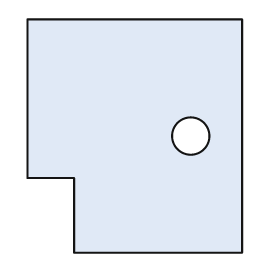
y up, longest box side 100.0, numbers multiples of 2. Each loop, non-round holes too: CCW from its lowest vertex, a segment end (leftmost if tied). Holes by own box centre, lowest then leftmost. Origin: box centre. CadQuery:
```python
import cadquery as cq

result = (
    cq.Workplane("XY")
    .moveTo(-26.0, -50.0)
    .lineTo(46.0, -50.0)
    .lineTo(46.0, 50.0)
    .lineTo(-46.0, 50.0)
    .lineTo(-46.0, -18.0)
    .lineTo(-26.0, -18.0)
    .close()
    .moveTo(24.0, 0.0)
    .circle(8.0)
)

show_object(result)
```